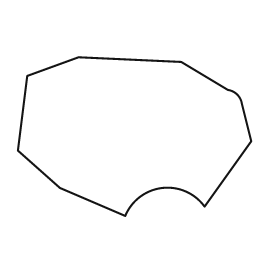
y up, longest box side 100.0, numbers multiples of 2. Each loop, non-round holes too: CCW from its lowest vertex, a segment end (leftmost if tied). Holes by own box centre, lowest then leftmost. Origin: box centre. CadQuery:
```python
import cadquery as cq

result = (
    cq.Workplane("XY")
    .moveTo(-4.0, -34.0)
    .threePointArc((12.0, -22.0), (30.0, -30.0))
    .lineTo(50.0, -2.0)
    .lineTo(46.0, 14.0)
    .threePointArc((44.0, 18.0), (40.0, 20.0))
    .lineTo(20.0, 32.0)
    .lineTo(-24.0, 34.0)
    .lineTo(-46.0, 26.0)
    .lineTo(-50.0, -6.0)
    .lineTo(-32.0, -22.0)
    .close()
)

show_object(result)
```